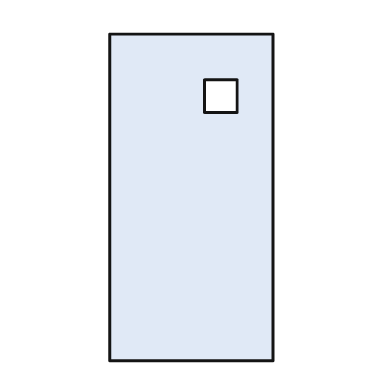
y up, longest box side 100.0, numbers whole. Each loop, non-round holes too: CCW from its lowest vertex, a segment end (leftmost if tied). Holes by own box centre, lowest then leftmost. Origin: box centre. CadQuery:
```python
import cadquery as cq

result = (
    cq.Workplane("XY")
    .moveTo(-25.0, -50.0)
    .lineTo(25.0, -50.0)
    .lineTo(25.0, 50.0)
    .lineTo(-25.0, 50.0)
    .close()
    .moveTo(4.0, 26.0)
    .lineTo(14.0, 26.0)
    .lineTo(14.0, 36.0)
    .lineTo(4.0, 36.0)
    .close()
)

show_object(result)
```